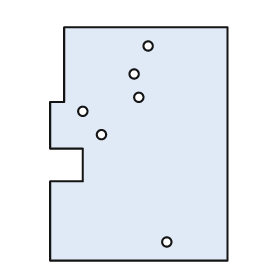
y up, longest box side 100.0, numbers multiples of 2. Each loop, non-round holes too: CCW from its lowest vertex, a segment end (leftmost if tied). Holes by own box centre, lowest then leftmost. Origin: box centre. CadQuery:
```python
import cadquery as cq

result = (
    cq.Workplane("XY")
    .moveTo(-38.0, -50.0)
    .lineTo(38.0, -50.0)
    .lineTo(38.0, 50.0)
    .lineTo(-32.0, 50.0)
    .lineTo(-32.0, 18.0)
    .lineTo(-38.0, 18.0)
    .lineTo(-38.0, -2.0)
    .lineTo(-24.0, -2.0)
    .lineTo(-24.0, -16.0)
    .lineTo(-38.0, -16.0)
    .close()
    .moveTo(12.0, -42.0)
    .circle(2.0)
    .moveTo(-16.0, 4.0)
    .circle(2.0)
    .moveTo(-24.0, 14.0)
    .circle(2.0)
    .moveTo(0.0, 20.0)
    .circle(2.0)
    .moveTo(-2.0, 30.0)
    .circle(2.0)
    .moveTo(4.0, 42.0)
    .circle(2.0)
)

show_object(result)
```